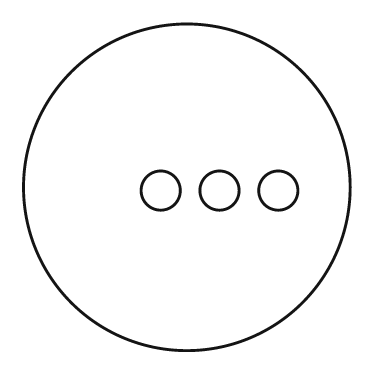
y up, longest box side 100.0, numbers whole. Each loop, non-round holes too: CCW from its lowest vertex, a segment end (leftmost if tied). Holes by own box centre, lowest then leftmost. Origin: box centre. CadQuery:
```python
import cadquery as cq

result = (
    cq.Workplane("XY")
    .moveTo(0.0, 0.0)
    .circle(50.0)
    .moveTo(-8.0, -1.0)
    .circle(6.0)
    .moveTo(10.0, -1.0)
    .circle(6.0)
    .moveTo(28.0, -1.0)
    .circle(6.0)
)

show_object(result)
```